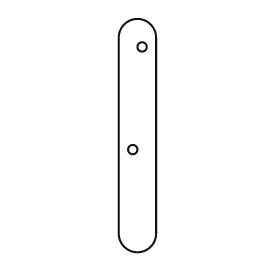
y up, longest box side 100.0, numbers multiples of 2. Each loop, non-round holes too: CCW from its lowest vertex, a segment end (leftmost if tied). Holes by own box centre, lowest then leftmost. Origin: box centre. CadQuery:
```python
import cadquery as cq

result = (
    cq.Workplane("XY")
    .moveTo(-8.0, -42.0)
    .threePointArc((0.0, -50.0), (8.0, -42.0))
    .lineTo(8.0, 42.0)
    .threePointArc((0.0, 50.0), (-8.0, 42.0))
    .close()
    .moveTo(-2.0, -6.0)
    .circle(2.0)
    .moveTo(2.0, 38.0)
    .circle(2.0)
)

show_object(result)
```